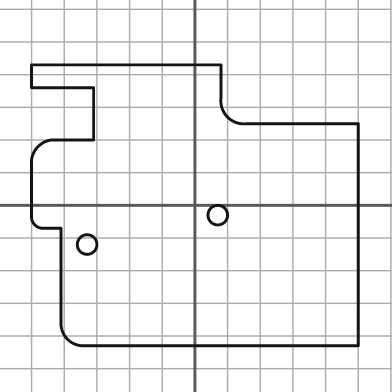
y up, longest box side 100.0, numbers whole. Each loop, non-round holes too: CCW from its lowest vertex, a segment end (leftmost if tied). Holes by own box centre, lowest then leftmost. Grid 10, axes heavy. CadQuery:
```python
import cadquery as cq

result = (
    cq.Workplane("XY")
    .moveTo(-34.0, -43.0)
    .lineTo(50.0, -43.0)
    .lineTo(50.0, 25.0)
    .lineTo(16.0, 25.0)
    .threePointArc((10.0, 27.0), (8.0, 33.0))
    .lineTo(8.0, 43.0)
    .lineTo(-50.0, 43.0)
    .lineTo(-50.0, 36.0)
    .lineTo(-31.0, 36.0)
    .lineTo(-31.0, 20.0)
    .lineTo(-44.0, 20.0)
    .threePointArc((-48.0, 18.0), (-50.0, 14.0))
    .lineTo(-50.0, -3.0)
    .threePointArc((-49.0, -6.0), (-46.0, -7.0))
    .lineTo(-41.0, -7.0)
    .lineTo(-41.0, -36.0)
    .threePointArc((-39.0, -41.0), (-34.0, -43.0))
    .close()
    .moveTo(-33.0, -12.0)
    .circle(3.0)
    .moveTo(7.0, -3.0)
    .circle(3.0)
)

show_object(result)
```